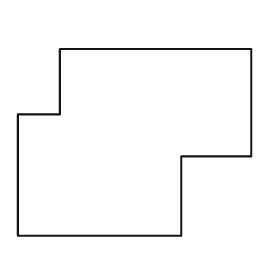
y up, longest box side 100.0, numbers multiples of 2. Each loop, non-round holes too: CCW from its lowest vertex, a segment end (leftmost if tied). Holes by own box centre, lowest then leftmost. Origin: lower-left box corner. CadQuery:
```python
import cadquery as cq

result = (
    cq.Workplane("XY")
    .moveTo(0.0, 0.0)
    .lineTo(70.0, 0.0)
    .lineTo(70.0, 34.0)
    .lineTo(100.0, 34.0)
    .lineTo(100.0, 80.0)
    .lineTo(18.0, 80.0)
    .lineTo(18.0, 52.0)
    .lineTo(0.0, 52.0)
    .close()
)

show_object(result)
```